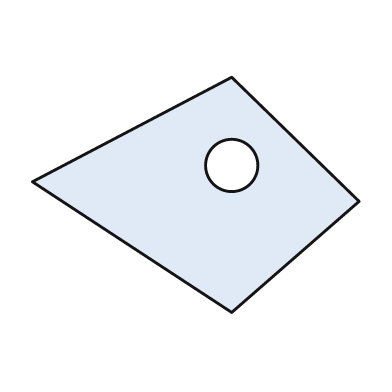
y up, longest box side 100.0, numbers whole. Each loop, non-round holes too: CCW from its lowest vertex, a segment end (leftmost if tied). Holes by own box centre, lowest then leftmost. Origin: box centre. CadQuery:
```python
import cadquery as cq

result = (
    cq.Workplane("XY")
    .moveTo(11.0, -36.0)
    .lineTo(50.0, -2.0)
    .lineTo(11.0, 36.0)
    .lineTo(-50.0, 4.0)
    .close()
    .moveTo(11.0, 9.0)
    .circle(8.0)
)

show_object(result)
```